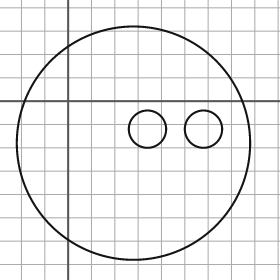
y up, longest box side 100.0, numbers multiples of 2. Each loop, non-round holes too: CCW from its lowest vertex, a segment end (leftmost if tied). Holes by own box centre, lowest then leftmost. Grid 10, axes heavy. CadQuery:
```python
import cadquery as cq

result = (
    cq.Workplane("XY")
    .moveTo(28.0, -18.0)
    .circle(50.0)
    .moveTo(34.0, -12.0)
    .circle(8.0)
    .moveTo(58.0, -12.0)
    .circle(8.0)
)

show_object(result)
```